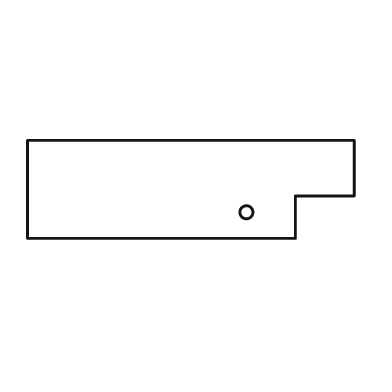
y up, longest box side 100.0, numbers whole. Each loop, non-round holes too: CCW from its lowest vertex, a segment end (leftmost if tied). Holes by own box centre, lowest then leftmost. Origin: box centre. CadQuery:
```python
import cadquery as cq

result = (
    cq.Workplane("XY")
    .moveTo(-50.0, -15.0)
    .lineTo(32.0, -15.0)
    .lineTo(32.0, -2.0)
    .lineTo(50.0, -2.0)
    .lineTo(50.0, 15.0)
    .lineTo(-50.0, 15.0)
    .close()
    .moveTo(17.0, -7.0)
    .circle(2.0)
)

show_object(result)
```